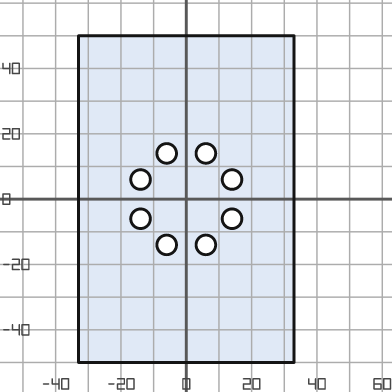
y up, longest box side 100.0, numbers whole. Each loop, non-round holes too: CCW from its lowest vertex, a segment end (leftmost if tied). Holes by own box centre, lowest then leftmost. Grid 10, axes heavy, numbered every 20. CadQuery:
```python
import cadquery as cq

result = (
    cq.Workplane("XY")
    .moveTo(-33.0, -50.0)
    .lineTo(33.0, -50.0)
    .lineTo(33.0, 50.0)
    .lineTo(-33.0, 50.0)
    .close()
    .moveTo(-6.0, -14.0)
    .circle(3.0)
    .moveTo(6.0, -14.0)
    .circle(3.0)
    .moveTo(-14.0, -6.0)
    .circle(3.0)
    .moveTo(14.0, -6.0)
    .circle(3.0)
    .moveTo(-14.0, 6.0)
    .circle(3.0)
    .moveTo(14.0, 6.0)
    .circle(3.0)
    .moveTo(-6.0, 14.0)
    .circle(3.0)
    .moveTo(6.0, 14.0)
    .circle(3.0)
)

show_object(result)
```